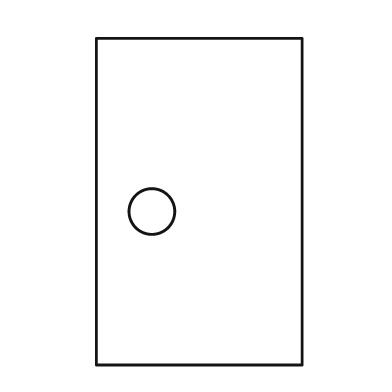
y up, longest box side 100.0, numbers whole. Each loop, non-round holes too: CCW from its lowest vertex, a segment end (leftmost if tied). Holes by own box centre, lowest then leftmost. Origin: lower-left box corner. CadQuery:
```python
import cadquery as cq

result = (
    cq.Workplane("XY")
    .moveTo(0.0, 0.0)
    .lineTo(63.0, 0.0)
    .lineTo(63.0, 100.0)
    .lineTo(0.0, 100.0)
    .close()
    .moveTo(17.0, 47.0)
    .circle(7.0)
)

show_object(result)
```